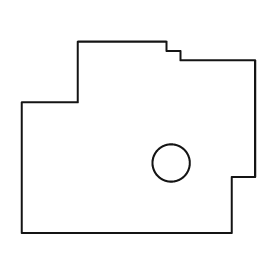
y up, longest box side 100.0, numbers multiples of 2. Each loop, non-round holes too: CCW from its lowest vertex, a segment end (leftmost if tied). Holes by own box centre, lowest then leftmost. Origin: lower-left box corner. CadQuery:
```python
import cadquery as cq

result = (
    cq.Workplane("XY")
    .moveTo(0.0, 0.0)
    .lineTo(90.0, 0.0)
    .lineTo(90.0, 24.0)
    .lineTo(100.0, 24.0)
    .lineTo(100.0, 74.0)
    .lineTo(68.0, 74.0)
    .lineTo(68.0, 78.0)
    .lineTo(62.0, 78.0)
    .lineTo(62.0, 82.0)
    .lineTo(24.0, 82.0)
    .lineTo(24.0, 56.0)
    .lineTo(0.0, 56.0)
    .close()
    .moveTo(64.0, 30.0)
    .circle(8.0)
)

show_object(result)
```